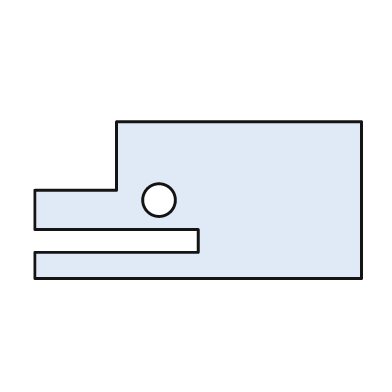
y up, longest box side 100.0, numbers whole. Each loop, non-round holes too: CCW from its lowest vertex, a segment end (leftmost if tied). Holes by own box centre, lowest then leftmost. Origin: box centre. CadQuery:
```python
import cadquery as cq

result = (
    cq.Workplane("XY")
    .moveTo(-50.0, -24.0)
    .lineTo(50.0, -24.0)
    .lineTo(50.0, 24.0)
    .lineTo(-25.0, 24.0)
    .lineTo(-25.0, 3.0)
    .lineTo(-50.0, 3.0)
    .lineTo(-50.0, -9.0)
    .lineTo(0.0, -9.0)
    .lineTo(0.0, -16.0)
    .lineTo(-50.0, -16.0)
    .close()
    .moveTo(-12.0, 0.0)
    .circle(5.0)
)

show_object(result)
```